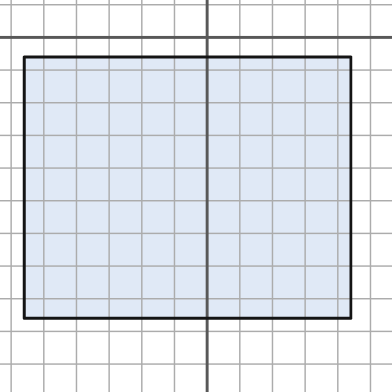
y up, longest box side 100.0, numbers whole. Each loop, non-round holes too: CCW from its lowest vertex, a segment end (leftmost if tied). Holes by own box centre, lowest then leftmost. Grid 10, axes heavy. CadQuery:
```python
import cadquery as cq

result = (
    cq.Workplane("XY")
    .moveTo(-56.0, -86.0)
    .lineTo(44.0, -86.0)
    .lineTo(44.0, -6.0)
    .lineTo(-56.0, -6.0)
    .close()
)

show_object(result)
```